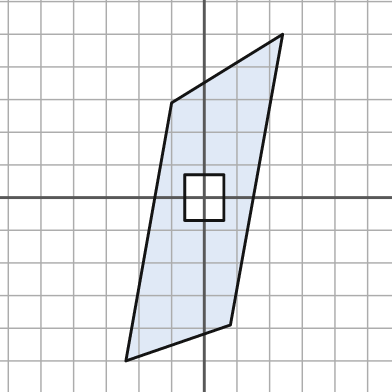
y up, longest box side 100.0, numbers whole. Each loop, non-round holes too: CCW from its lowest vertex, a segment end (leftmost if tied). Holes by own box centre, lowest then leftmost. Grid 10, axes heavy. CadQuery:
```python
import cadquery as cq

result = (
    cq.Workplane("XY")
    .moveTo(-24.0, -50.0)
    .lineTo(8.0, -39.0)
    .lineTo(24.0, 50.0)
    .lineTo(-10.0, 29.0)
    .close()
    .moveTo(-6.0, -7.0)
    .lineTo(6.0, -7.0)
    .lineTo(6.0, 7.0)
    .lineTo(-6.0, 7.0)
    .close()
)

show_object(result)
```